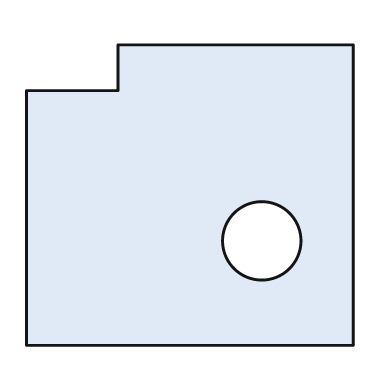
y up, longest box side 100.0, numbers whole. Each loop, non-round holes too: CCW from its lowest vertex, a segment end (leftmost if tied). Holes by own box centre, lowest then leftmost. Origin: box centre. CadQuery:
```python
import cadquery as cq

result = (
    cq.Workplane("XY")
    .moveTo(-50.0, -46.0)
    .lineTo(50.0, -46.0)
    .lineTo(50.0, 46.0)
    .lineTo(-22.0, 46.0)
    .lineTo(-22.0, 32.0)
    .lineTo(-50.0, 32.0)
    .close()
    .moveTo(22.0, -14.0)
    .circle(12.0)
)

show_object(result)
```